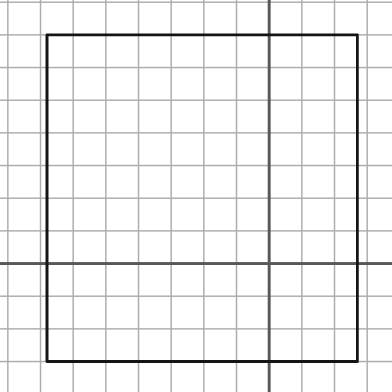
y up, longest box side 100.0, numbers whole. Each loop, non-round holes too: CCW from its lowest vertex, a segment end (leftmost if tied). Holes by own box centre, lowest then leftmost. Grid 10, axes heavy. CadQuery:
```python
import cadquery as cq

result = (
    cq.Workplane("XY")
    .moveTo(-68.0, -30.0)
    .lineTo(27.0, -30.0)
    .lineTo(27.0, 70.0)
    .lineTo(-68.0, 70.0)
    .close()
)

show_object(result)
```